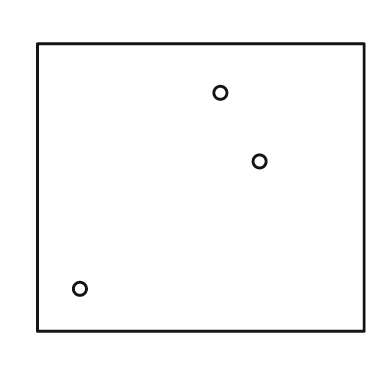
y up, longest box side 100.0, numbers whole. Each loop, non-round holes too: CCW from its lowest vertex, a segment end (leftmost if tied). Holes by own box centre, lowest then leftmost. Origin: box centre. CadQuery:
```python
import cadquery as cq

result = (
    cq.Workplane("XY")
    .moveTo(-50.0, -44.0)
    .lineTo(50.0, -44.0)
    .lineTo(50.0, 44.0)
    .lineTo(-50.0, 44.0)
    .close()
    .moveTo(-37.0, -31.0)
    .circle(2.0)
    .moveTo(18.0, 8.0)
    .circle(2.0)
    .moveTo(6.0, 29.0)
    .circle(2.0)
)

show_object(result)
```